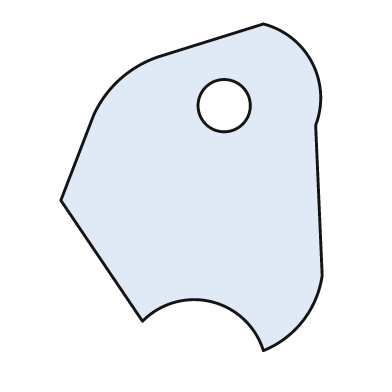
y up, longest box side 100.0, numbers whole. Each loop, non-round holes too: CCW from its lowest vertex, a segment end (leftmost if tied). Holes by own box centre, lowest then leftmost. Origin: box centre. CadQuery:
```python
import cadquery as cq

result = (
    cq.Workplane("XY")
    .moveTo(22.0, -50.0)
    .threePointArc((34.0, -41.0), (40.0, -27.0))
    .lineTo(38.0, 19.0)
    .threePointArc((37.0, 38.0), (22.0, 50.0))
    .lineTo(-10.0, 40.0)
    .threePointArc((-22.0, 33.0), (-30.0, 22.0))
    .lineTo(-40.0, -4.0)
    .lineTo(-15.0, -41.0)
    .threePointArc((6.0, -35.0), (22.0, -50.0))
    .close()
    .moveTo(10.0, 25.0)
    .circle(8.0)
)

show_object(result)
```